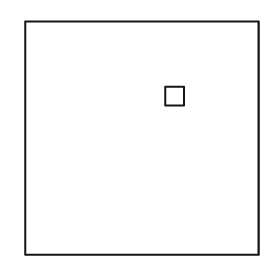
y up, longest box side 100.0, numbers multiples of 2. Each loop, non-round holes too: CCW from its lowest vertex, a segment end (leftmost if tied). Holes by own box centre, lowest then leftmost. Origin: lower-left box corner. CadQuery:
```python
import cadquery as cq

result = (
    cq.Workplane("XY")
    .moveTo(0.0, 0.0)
    .lineTo(100.0, 0.0)
    .lineTo(100.0, 100.0)
    .lineTo(0.0, 100.0)
    .close()
    .moveTo(60.0, 64.0)
    .lineTo(68.0, 64.0)
    .lineTo(68.0, 72.0)
    .lineTo(60.0, 72.0)
    .close()
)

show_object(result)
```